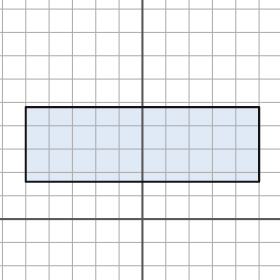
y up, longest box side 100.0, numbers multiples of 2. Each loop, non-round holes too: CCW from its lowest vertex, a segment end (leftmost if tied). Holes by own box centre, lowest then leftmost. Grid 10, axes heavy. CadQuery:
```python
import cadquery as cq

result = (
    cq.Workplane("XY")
    .moveTo(-50.0, 16.0)
    .lineTo(50.0, 16.0)
    .lineTo(50.0, 48.0)
    .lineTo(-50.0, 48.0)
    .close()
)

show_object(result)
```